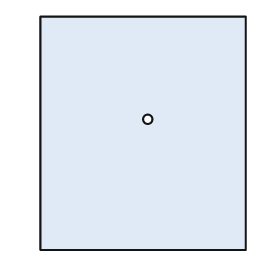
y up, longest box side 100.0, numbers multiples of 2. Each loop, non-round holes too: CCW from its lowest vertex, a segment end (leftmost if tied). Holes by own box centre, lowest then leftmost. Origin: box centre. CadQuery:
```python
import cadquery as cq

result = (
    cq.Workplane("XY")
    .moveTo(-44.0, -50.0)
    .lineTo(44.0, -50.0)
    .lineTo(44.0, 50.0)
    .lineTo(-44.0, 50.0)
    .close()
    .moveTo(2.0, 6.0)
    .circle(2.0)
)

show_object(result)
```